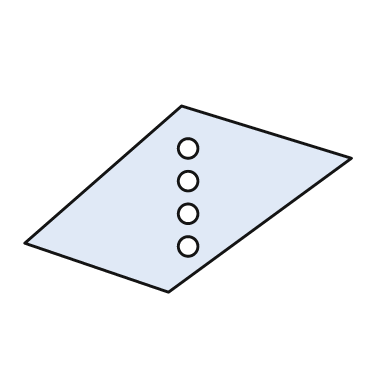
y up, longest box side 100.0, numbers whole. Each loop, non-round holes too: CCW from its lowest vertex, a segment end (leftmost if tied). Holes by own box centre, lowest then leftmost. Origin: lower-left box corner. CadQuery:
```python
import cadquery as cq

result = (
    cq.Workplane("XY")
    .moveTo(44.0, 0.0)
    .lineTo(100.0, 41.0)
    .lineTo(48.0, 57.0)
    .lineTo(0.0, 15.0)
    .close()
    .moveTo(50.0, 14.0)
    .circle(3.0)
    .moveTo(50.0, 24.0)
    .circle(3.0)
    .moveTo(50.0, 34.0)
    .circle(3.0)
    .moveTo(50.0, 44.0)
    .circle(3.0)
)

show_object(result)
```